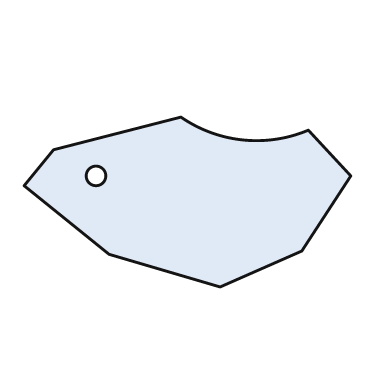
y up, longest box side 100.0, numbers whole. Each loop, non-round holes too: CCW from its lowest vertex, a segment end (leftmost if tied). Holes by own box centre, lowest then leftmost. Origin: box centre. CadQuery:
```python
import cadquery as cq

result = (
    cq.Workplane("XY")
    .moveTo(10.0, -26.0)
    .lineTo(35.0, -15.0)
    .lineTo(50.0, 8.0)
    .lineTo(37.0, 22.0)
    .threePointArc((17.0, 19.0), (-2.0, 26.0))
    .lineTo(-41.0, 16.0)
    .lineTo(-50.0, 5.0)
    .lineTo(-24.0, -16.0)
    .close()
    .moveTo(-28.0, 8.0)
    .circle(3.0)
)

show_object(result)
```